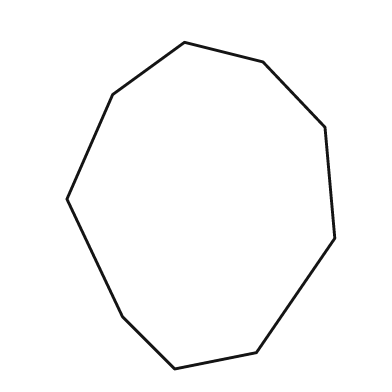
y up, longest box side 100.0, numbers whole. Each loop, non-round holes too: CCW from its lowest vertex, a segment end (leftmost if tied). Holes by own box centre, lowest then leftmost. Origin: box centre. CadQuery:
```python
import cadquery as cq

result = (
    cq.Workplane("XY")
    .moveTo(-8.0, -50.0)
    .lineTo(17.0, -45.0)
    .lineTo(41.0, -10.0)
    .lineTo(38.0, 24.0)
    .lineTo(19.0, 44.0)
    .lineTo(-5.0, 50.0)
    .lineTo(-27.0, 34.0)
    .lineTo(-41.0, 2.0)
    .lineTo(-24.0, -34.0)
    .close()
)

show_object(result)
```